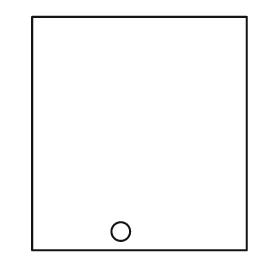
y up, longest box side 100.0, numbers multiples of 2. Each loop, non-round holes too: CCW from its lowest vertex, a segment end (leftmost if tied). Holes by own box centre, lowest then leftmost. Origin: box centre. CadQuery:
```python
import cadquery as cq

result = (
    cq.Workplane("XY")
    .moveTo(-46.0, -50.0)
    .lineTo(46.0, -50.0)
    .lineTo(46.0, 50.0)
    .lineTo(-46.0, 50.0)
    .close()
    .moveTo(-8.0, -42.0)
    .circle(4.0)
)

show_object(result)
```